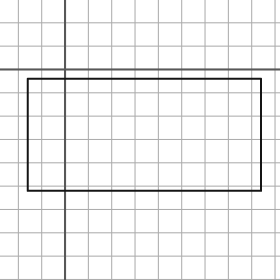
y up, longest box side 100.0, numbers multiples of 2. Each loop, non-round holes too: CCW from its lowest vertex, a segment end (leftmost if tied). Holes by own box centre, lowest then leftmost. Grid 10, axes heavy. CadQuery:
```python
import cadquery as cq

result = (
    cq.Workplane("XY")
    .moveTo(-16.0, -52.0)
    .lineTo(84.0, -52.0)
    .lineTo(84.0, -4.0)
    .lineTo(-16.0, -4.0)
    .close()
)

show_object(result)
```